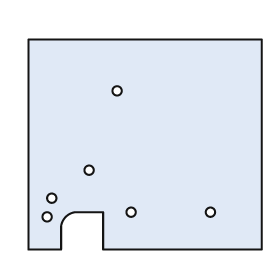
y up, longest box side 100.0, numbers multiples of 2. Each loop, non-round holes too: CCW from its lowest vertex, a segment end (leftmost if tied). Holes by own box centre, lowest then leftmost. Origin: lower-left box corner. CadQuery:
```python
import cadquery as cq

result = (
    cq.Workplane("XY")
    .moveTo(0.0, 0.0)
    .lineTo(14.0, 0.0)
    .lineTo(14.0, 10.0)
    .threePointArc((16.0, 14.0), (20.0, 16.0))
    .lineTo(32.0, 16.0)
    .lineTo(32.0, 0.0)
    .lineTo(100.0, 0.0)
    .lineTo(100.0, 90.0)
    .lineTo(0.0, 90.0)
    .close()
    .moveTo(8.0, 14.0)
    .circle(2.0)
    .moveTo(44.0, 16.0)
    .circle(2.0)
    .moveTo(78.0, 16.0)
    .circle(2.0)
    .moveTo(10.0, 22.0)
    .circle(2.0)
    .moveTo(26.0, 34.0)
    .circle(2.0)
    .moveTo(38.0, 68.0)
    .circle(2.0)
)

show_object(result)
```